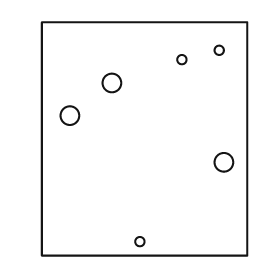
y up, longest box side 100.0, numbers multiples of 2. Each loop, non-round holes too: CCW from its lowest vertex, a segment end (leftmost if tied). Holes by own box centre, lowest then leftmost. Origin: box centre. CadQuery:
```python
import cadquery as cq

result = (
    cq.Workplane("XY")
    .moveTo(-44.0, -50.0)
    .lineTo(44.0, -50.0)
    .lineTo(44.0, 50.0)
    .lineTo(-44.0, 50.0)
    .close()
    .moveTo(-2.0, -44.0)
    .circle(2.0)
    .moveTo(34.0, -10.0)
    .circle(4.0)
    .moveTo(-32.0, 10.0)
    .circle(4.0)
    .moveTo(-14.0, 24.0)
    .circle(4.0)
    .moveTo(16.0, 34.0)
    .circle(2.0)
    .moveTo(32.0, 38.0)
    .circle(2.0)
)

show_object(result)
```